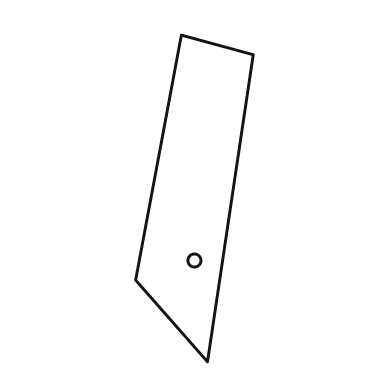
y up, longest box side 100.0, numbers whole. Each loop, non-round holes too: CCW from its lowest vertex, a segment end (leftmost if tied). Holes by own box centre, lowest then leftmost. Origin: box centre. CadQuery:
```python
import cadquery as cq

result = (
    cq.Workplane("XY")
    .moveTo(4.0, -50.0)
    .lineTo(18.0, 44.0)
    .lineTo(-4.0, 50.0)
    .lineTo(-18.0, -25.0)
    .close()
    .moveTo(0.0, -19.0)
    .circle(2.0)
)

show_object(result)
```